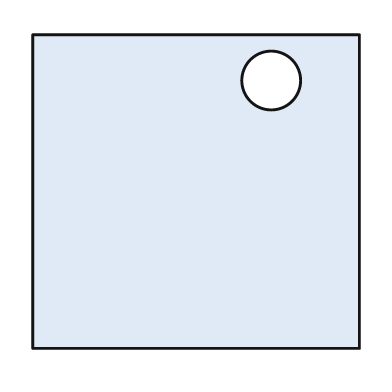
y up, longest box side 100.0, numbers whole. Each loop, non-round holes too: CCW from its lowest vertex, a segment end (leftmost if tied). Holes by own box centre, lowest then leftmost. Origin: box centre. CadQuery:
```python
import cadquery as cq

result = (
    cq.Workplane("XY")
    .moveTo(-50.0, -48.0)
    .lineTo(50.0, -48.0)
    .lineTo(50.0, 48.0)
    .lineTo(-50.0, 48.0)
    .close()
    .moveTo(23.0, 34.0)
    .circle(9.0)
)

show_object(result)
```